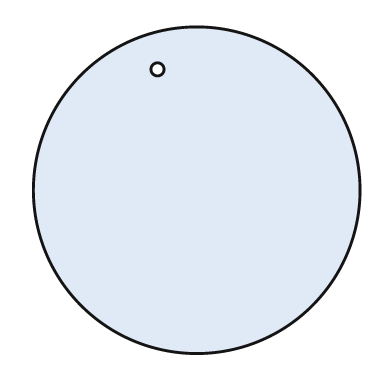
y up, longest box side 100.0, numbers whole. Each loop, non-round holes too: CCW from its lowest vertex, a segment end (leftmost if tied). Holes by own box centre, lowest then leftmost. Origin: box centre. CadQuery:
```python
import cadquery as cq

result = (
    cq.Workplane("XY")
    .moveTo(0.0, 0.0)
    .circle(50.0)
    .moveTo(-12.0, 37.0)
    .circle(2.0)
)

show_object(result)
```